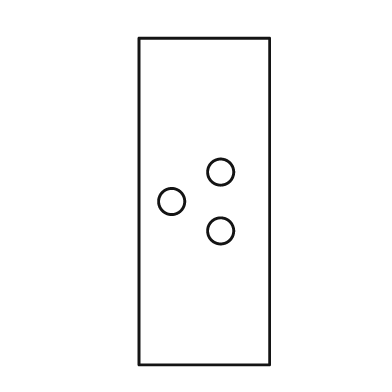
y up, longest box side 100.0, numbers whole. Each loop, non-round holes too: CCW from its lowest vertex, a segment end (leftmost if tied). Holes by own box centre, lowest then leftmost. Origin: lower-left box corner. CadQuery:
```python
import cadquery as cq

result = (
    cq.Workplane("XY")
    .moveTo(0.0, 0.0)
    .lineTo(40.0, 0.0)
    .lineTo(40.0, 100.0)
    .lineTo(0.0, 100.0)
    .close()
    .moveTo(25.0, 41.0)
    .circle(4.0)
    .moveTo(10.0, 50.0)
    .circle(4.0)
    .moveTo(25.0, 59.0)
    .circle(4.0)
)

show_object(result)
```